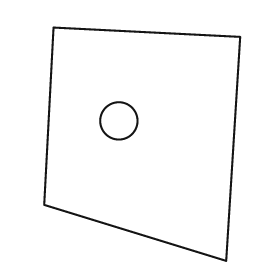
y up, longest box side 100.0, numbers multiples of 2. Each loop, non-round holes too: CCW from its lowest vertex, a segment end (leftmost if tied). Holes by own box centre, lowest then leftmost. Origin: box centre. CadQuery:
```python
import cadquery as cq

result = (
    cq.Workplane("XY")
    .moveTo(36.0, -50.0)
    .lineTo(42.0, 46.0)
    .lineTo(-38.0, 50.0)
    .lineTo(-42.0, -26.0)
    .close()
    .moveTo(-10.0, 10.0)
    .circle(8.0)
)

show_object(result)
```